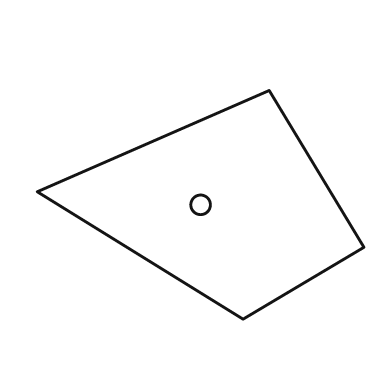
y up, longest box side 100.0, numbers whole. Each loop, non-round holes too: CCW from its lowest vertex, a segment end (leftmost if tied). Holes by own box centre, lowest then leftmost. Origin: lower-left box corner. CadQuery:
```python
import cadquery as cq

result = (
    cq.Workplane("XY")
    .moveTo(63.0, 0.0)
    .lineTo(100.0, 22.0)
    .lineTo(71.0, 70.0)
    .lineTo(0.0, 39.0)
    .close()
    .moveTo(50.0, 35.0)
    .circle(3.0)
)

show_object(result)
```